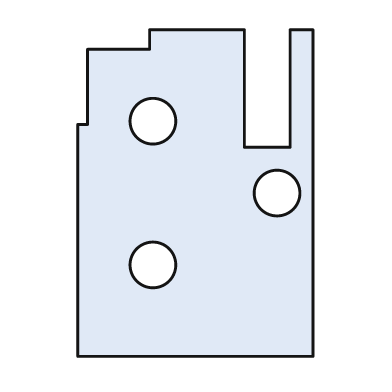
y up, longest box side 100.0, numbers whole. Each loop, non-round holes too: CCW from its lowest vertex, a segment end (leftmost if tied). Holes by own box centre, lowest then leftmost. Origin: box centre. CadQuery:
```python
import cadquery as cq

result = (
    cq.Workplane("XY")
    .moveTo(-36.0, -50.0)
    .lineTo(36.0, -50.0)
    .lineTo(36.0, 50.0)
    .lineTo(29.0, 50.0)
    .lineTo(29.0, 14.0)
    .lineTo(15.0, 14.0)
    .lineTo(15.0, 50.0)
    .lineTo(-14.0, 50.0)
    .lineTo(-14.0, 44.0)
    .lineTo(-33.0, 44.0)
    .lineTo(-33.0, 21.0)
    .lineTo(-36.0, 21.0)
    .close()
    .moveTo(-13.0, -22.0)
    .circle(7.0)
    .moveTo(25.0, 0.0)
    .circle(7.0)
    .moveTo(-13.0, 22.0)
    .circle(7.0)
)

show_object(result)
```